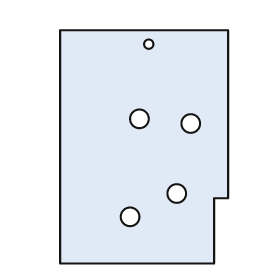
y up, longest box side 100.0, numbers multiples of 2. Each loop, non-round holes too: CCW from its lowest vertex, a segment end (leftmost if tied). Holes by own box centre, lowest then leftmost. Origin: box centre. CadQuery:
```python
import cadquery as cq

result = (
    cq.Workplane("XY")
    .moveTo(-36.0, -50.0)
    .lineTo(30.0, -50.0)
    .lineTo(30.0, -22.0)
    .lineTo(36.0, -22.0)
    .lineTo(36.0, 50.0)
    .lineTo(-36.0, 50.0)
    .close()
    .moveTo(-6.0, -30.0)
    .circle(4.0)
    .moveTo(14.0, -20.0)
    .circle(4.0)
    .moveTo(20.0, 10.0)
    .circle(4.0)
    .moveTo(-2.0, 12.0)
    .circle(4.0)
    .moveTo(2.0, 44.0)
    .circle(2.0)
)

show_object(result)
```